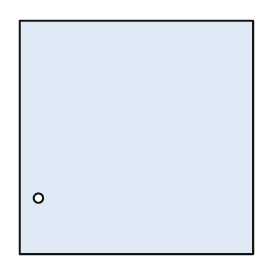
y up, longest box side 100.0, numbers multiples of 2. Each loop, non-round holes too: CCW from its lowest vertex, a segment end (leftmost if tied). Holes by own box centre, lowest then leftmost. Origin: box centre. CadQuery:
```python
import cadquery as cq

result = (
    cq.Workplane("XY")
    .moveTo(-50.0, -50.0)
    .lineTo(50.0, -50.0)
    .lineTo(50.0, 50.0)
    .lineTo(-50.0, 50.0)
    .close()
    .moveTo(-42.0, -26.0)
    .circle(2.0)
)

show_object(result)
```